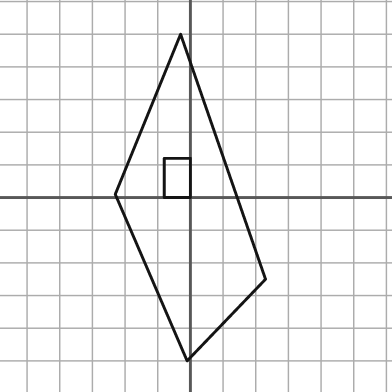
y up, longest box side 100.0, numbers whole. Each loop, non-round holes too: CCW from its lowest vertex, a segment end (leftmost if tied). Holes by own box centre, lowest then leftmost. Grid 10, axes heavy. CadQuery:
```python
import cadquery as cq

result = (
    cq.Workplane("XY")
    .moveTo(-1.0, -50.0)
    .lineTo(23.0, -25.0)
    .lineTo(-3.0, 50.0)
    .lineTo(-23.0, 1.0)
    .close()
    .moveTo(-8.0, 0.0)
    .lineTo(0.0, 0.0)
    .lineTo(0.0, 12.0)
    .lineTo(-8.0, 12.0)
    .close()
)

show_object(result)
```